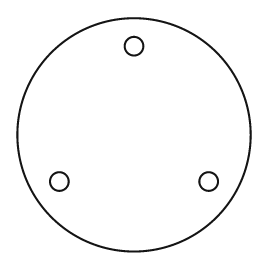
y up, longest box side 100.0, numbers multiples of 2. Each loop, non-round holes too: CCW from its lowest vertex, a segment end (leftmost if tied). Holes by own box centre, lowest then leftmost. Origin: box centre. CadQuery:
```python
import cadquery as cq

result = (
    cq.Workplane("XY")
    .moveTo(0.0, 0.0)
    .circle(50.0)
    .moveTo(-32.0, -20.0)
    .circle(4.0)
    .moveTo(32.0, -20.0)
    .circle(4.0)
    .moveTo(0.0, 38.0)
    .circle(4.0)
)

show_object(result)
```